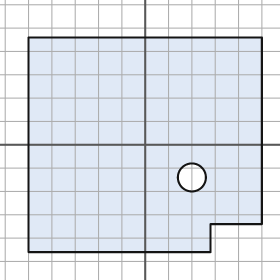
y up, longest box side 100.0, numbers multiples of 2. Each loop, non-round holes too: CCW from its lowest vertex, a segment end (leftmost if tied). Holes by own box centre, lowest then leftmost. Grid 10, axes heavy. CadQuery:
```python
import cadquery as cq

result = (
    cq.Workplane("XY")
    .moveTo(-50.0, -46.0)
    .lineTo(28.0, -46.0)
    .lineTo(28.0, -34.0)
    .lineTo(50.0, -34.0)
    .lineTo(50.0, 46.0)
    .lineTo(-50.0, 46.0)
    .close()
    .moveTo(20.0, -14.0)
    .circle(6.0)
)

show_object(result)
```